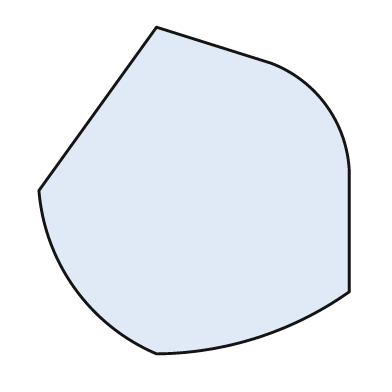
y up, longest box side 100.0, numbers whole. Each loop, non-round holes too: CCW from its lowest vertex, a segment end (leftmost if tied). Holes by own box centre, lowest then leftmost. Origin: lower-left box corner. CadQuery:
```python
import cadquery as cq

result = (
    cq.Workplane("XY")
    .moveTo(36.0, 0.0)
    .threePointArc((67.0, 5.0), (95.0, 19.0))
    .lineTo(95.0, 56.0)
    .threePointArc((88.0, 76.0), (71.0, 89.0))
    .lineTo(36.0, 100.0)
    .lineTo(0.0, 50.0)
    .threePointArc((11.0, 20.0), (36.0, 0.0))
    .close()
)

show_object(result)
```